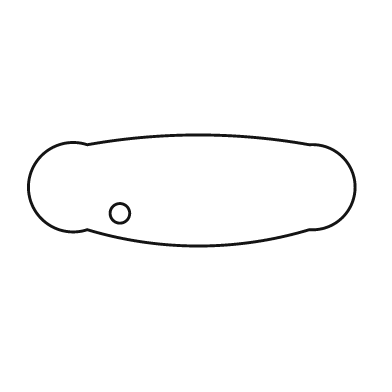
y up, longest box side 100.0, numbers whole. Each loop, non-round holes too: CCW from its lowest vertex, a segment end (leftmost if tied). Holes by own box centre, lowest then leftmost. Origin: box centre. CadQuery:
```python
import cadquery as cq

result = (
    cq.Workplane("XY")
    .moveTo(-32.0, -12.0)
    .threePointArc((2.0, -17.0), (36.0, -12.0))
    .threePointArc((50.0, 1.0), (36.0, 14.0))
    .threePointArc((2.0, 17.0), (-32.0, 14.0))
    .threePointArc((-50.0, 1.0), (-32.0, -12.0))
    .close()
    .moveTo(-22.0, -7.0)
    .circle(3.0)
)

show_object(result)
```